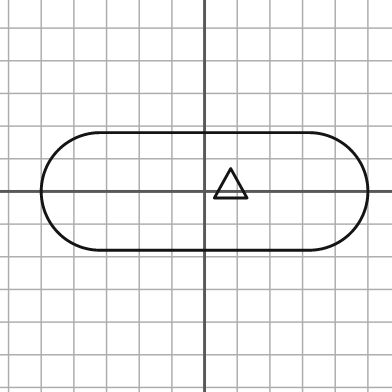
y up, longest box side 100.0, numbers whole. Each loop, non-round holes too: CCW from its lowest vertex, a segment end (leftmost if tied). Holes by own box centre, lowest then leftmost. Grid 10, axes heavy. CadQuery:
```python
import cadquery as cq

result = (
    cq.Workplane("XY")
    .moveTo(-32.0, -18.0)
    .lineTo(32.0, -18.0)
    .threePointArc((50.0, 0.0), (32.0, 18.0))
    .lineTo(-32.0, 18.0)
    .threePointArc((-50.0, 0.0), (-32.0, -18.0))
    .close()
    .moveTo(3.0, -2.0)
    .lineTo(13.0, -2.0)
    .lineTo(8.0, 7.0)
    .close()
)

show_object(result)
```